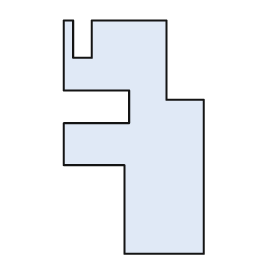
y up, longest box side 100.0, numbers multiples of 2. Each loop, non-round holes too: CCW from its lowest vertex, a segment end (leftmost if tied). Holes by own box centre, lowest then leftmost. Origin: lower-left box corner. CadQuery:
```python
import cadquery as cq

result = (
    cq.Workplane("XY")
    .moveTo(26.0, 0.0)
    .lineTo(60.0, 0.0)
    .lineTo(60.0, 66.0)
    .lineTo(44.0, 66.0)
    .lineTo(44.0, 100.0)
    .lineTo(12.0, 100.0)
    .lineTo(12.0, 84.0)
    .lineTo(4.0, 84.0)
    .lineTo(4.0, 100.0)
    .lineTo(0.0, 100.0)
    .lineTo(0.0, 70.0)
    .lineTo(28.0, 70.0)
    .lineTo(28.0, 56.0)
    .lineTo(0.0, 56.0)
    .lineTo(0.0, 38.0)
    .lineTo(26.0, 38.0)
    .close()
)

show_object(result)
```